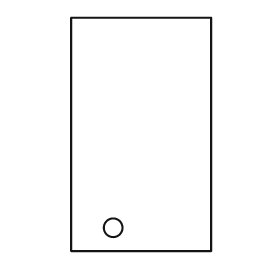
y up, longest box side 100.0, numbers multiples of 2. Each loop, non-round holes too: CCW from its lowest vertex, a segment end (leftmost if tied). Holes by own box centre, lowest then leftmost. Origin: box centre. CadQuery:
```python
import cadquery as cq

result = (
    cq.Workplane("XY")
    .moveTo(-30.0, -50.0)
    .lineTo(30.0, -50.0)
    .lineTo(30.0, 50.0)
    .lineTo(-30.0, 50.0)
    .close()
    .moveTo(-12.0, -40.0)
    .circle(4.0)
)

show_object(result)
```